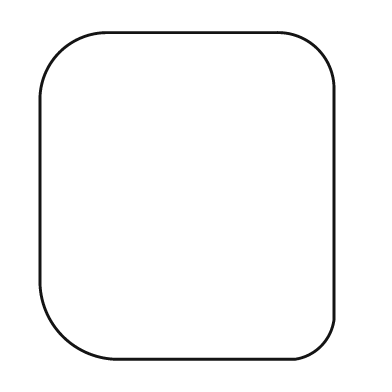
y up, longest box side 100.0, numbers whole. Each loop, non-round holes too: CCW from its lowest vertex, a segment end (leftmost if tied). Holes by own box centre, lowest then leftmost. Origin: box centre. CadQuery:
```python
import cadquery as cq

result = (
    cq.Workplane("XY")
    .moveTo(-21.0, -50.0)
    .lineTo(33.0, -50.0)
    .threePointArc((41.0, -46.0), (45.0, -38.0))
    .lineTo(45.0, 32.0)
    .threePointArc((40.0, 45.0), (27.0, 50.0))
    .lineTo(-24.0, 50.0)
    .threePointArc((-39.0, 44.0), (-45.0, 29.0))
    .lineTo(-45.0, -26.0)
    .threePointArc((-38.0, -43.0), (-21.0, -50.0))
    .close()
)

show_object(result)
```